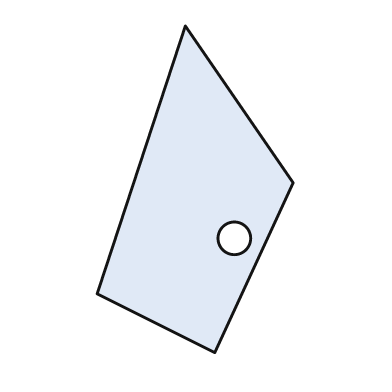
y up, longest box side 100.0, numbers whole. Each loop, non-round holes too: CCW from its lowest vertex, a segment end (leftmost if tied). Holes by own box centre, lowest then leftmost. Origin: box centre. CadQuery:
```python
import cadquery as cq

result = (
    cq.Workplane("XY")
    .moveTo(6.0, -50.0)
    .lineTo(30.0, 2.0)
    .lineTo(-3.0, 50.0)
    .lineTo(-30.0, -32.0)
    .close()
    .moveTo(12.0, -15.0)
    .circle(5.0)
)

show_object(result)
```